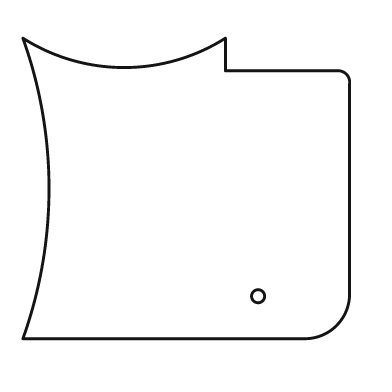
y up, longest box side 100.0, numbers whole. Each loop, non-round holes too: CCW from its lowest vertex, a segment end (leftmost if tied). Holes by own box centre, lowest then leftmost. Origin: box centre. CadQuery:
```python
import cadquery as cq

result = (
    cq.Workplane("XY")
    .moveTo(-50.0, -46.0)
    .lineTo(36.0, -46.0)
    .threePointArc((46.0, -42.0), (50.0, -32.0))
    .lineTo(50.0, 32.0)
    .threePointArc((49.0, 35.0), (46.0, 36.0))
    .lineTo(12.0, 36.0)
    .lineTo(12.0, 46.0)
    .threePointArc((-19.0, 37.0), (-50.0, 46.0))
    .threePointArc((-42.0, 0.0), (-50.0, -46.0))
    .close()
    .moveTo(22.0, -33.0)
    .circle(2.0)
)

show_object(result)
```